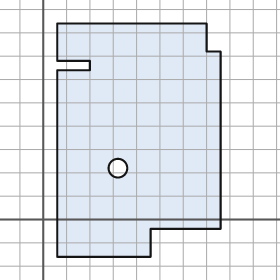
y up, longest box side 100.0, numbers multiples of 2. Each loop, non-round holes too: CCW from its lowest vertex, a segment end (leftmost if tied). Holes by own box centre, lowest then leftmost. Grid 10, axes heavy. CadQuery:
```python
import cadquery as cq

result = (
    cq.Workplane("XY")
    .moveTo(6.0, -16.0)
    .lineTo(46.0, -16.0)
    .lineTo(46.0, -4.0)
    .lineTo(76.0, -4.0)
    .lineTo(76.0, 72.0)
    .lineTo(70.0, 72.0)
    .lineTo(70.0, 84.0)
    .lineTo(6.0, 84.0)
    .lineTo(6.0, 68.0)
    .lineTo(20.0, 68.0)
    .lineTo(20.0, 64.0)
    .lineTo(6.0, 64.0)
    .close()
    .moveTo(32.0, 22.0)
    .circle(4.0)
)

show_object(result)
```